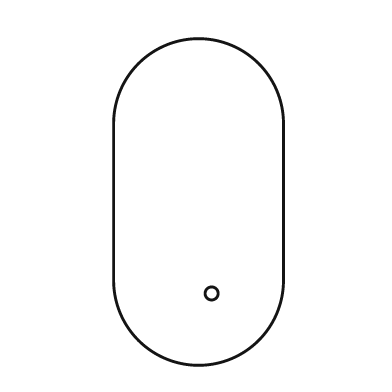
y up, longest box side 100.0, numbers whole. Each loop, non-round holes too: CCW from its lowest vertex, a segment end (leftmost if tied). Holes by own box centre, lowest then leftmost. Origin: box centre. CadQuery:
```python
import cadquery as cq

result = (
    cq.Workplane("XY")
    .moveTo(-26.0, -24.0)
    .threePointArc((0.0, -50.0), (26.0, -24.0))
    .lineTo(26.0, 24.0)
    .threePointArc((0.0, 50.0), (-26.0, 24.0))
    .close()
    .moveTo(4.0, -28.0)
    .circle(2.0)
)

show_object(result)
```